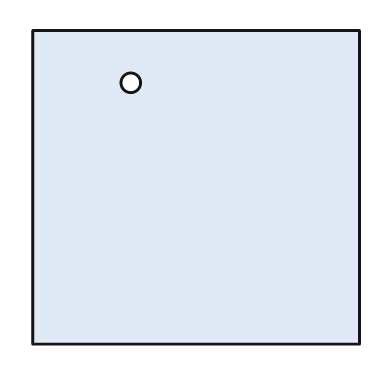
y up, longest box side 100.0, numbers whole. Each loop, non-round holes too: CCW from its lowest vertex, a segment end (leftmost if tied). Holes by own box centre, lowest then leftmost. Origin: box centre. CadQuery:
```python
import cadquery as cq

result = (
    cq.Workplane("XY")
    .moveTo(-50.0, -48.0)
    .lineTo(50.0, -48.0)
    .lineTo(50.0, 48.0)
    .lineTo(-50.0, 48.0)
    .close()
    .moveTo(-20.0, 32.0)
    .circle(3.0)
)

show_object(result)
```